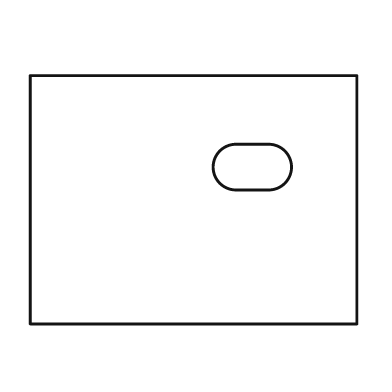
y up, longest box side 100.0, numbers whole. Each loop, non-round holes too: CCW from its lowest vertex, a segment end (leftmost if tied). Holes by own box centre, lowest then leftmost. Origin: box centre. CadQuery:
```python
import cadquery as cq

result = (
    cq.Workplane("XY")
    .moveTo(-50.0, -38.0)
    .lineTo(50.0, -38.0)
    .lineTo(50.0, 38.0)
    .lineTo(-50.0, 38.0)
    .close()
    .moveTo(13.0, 3.0)
    .lineTo(23.0, 3.0)
    .threePointArc((30.0, 10.0), (23.0, 17.0))
    .lineTo(13.0, 17.0)
    .threePointArc((6.0, 10.0), (13.0, 3.0))
    .close()
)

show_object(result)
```